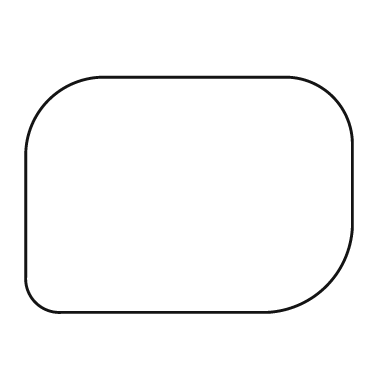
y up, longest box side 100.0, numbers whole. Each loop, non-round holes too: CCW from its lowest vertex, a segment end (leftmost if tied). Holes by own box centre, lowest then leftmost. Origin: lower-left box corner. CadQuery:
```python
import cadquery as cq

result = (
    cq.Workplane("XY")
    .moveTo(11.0, 0.0)
    .lineTo(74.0, 0.0)
    .threePointArc((92.0, 8.0), (100.0, 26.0))
    .lineTo(100.0, 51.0)
    .threePointArc((94.0, 66.0), (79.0, 72.0))
    .lineTo(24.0, 72.0)
    .threePointArc((7.0, 65.0), (0.0, 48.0))
    .lineTo(0.0, 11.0)
    .threePointArc((3.0, 3.0), (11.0, 0.0))
    .close()
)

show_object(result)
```